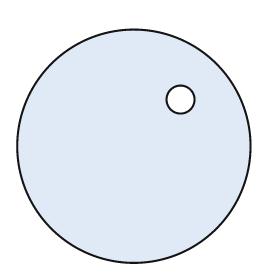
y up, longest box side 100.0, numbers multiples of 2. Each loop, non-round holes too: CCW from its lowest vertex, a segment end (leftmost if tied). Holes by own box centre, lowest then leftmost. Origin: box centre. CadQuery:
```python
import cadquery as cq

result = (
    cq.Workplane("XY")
    .moveTo(0.0, 0.0)
    .circle(50.0)
    .moveTo(20.0, 20.0)
    .circle(6.0)
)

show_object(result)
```